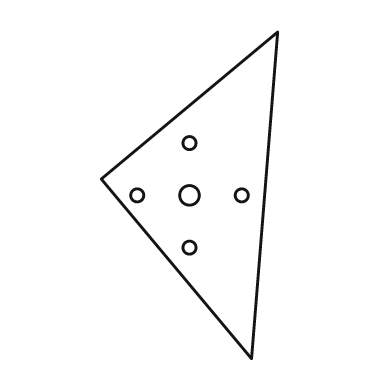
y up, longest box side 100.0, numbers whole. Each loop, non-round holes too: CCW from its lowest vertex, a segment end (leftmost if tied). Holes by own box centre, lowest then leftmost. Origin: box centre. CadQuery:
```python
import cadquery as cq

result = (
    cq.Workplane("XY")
    .moveTo(19.0, -50.0)
    .lineTo(27.0, 50.0)
    .lineTo(-27.0, 5.0)
    .close()
    .moveTo(0.0, -16.0)
    .circle(2.0)
    .moveTo(-16.0, 0.0)
    .circle(2.0)
    .moveTo(0.0, 0.0)
    .circle(3.0)
    .moveTo(16.0, 0.0)
    .circle(2.0)
    .moveTo(0.0, 16.0)
    .circle(2.0)
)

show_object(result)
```